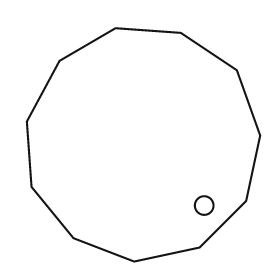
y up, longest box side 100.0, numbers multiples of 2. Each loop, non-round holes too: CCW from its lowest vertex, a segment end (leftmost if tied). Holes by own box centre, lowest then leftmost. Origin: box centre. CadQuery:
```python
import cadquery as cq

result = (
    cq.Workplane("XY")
    .moveTo(-4.0, -50.0)
    .lineTo(24.0, -44.0)
    .lineTo(44.0, -24.0)
    .lineTo(50.0, 4.0)
    .lineTo(40.0, 32.0)
    .lineTo(16.0, 48.0)
    .lineTo(-12.0, 50.0)
    .lineTo(-36.0, 36.0)
    .lineTo(-50.0, 10.0)
    .lineTo(-48.0, -18.0)
    .lineTo(-30.0, -40.0)
    .close()
    .moveTo(26.0, -26.0)
    .circle(4.0)
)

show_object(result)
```